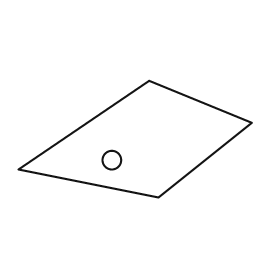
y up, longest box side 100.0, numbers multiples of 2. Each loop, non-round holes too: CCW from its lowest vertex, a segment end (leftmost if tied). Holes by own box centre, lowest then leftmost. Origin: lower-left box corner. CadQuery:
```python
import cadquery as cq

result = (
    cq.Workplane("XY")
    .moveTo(60.0, 0.0)
    .lineTo(100.0, 32.0)
    .lineTo(56.0, 50.0)
    .lineTo(0.0, 12.0)
    .close()
    .moveTo(40.0, 16.0)
    .circle(4.0)
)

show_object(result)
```